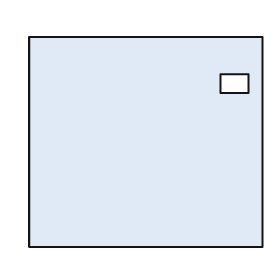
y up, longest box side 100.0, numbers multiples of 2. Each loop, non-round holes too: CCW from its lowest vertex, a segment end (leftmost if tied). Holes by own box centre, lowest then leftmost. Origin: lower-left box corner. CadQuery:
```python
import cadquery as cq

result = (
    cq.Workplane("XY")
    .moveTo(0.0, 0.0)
    .lineTo(100.0, 0.0)
    .lineTo(100.0, 90.0)
    .lineTo(0.0, 90.0)
    .close()
    .moveTo(82.0, 66.0)
    .lineTo(94.0, 66.0)
    .lineTo(94.0, 74.0)
    .lineTo(82.0, 74.0)
    .close()
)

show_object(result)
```